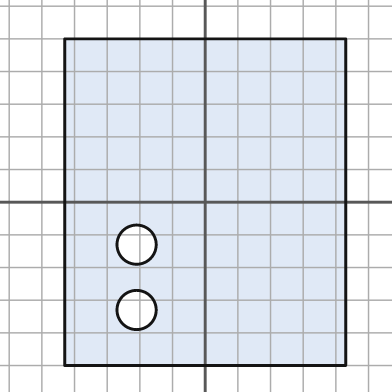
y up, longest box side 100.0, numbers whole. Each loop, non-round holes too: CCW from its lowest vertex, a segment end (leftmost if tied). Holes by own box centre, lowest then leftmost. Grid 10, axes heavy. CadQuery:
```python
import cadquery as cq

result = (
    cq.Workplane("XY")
    .moveTo(-43.0, -50.0)
    .lineTo(43.0, -50.0)
    .lineTo(43.0, 50.0)
    .lineTo(-43.0, 50.0)
    .close()
    .moveTo(-21.0, -33.0)
    .circle(6.0)
    .moveTo(-21.0, -13.0)
    .circle(6.0)
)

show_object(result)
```